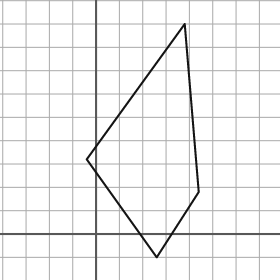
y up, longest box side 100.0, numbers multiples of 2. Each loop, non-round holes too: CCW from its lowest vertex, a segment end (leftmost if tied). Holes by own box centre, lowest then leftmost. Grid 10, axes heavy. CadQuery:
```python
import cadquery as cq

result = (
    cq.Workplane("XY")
    .moveTo(26.0, -10.0)
    .lineTo(44.0, 18.0)
    .lineTo(38.0, 90.0)
    .lineTo(-4.0, 32.0)
    .close()
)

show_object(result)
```